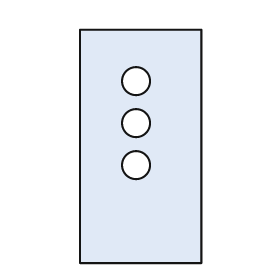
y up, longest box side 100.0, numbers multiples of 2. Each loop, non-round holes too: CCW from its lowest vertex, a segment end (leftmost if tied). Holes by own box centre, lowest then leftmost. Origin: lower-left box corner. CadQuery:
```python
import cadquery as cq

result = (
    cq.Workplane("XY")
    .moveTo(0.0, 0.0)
    .lineTo(52.0, 0.0)
    .lineTo(52.0, 100.0)
    .lineTo(0.0, 100.0)
    .close()
    .moveTo(24.0, 42.0)
    .circle(6.0)
    .moveTo(24.0, 60.0)
    .circle(6.0)
    .moveTo(24.0, 78.0)
    .circle(6.0)
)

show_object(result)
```